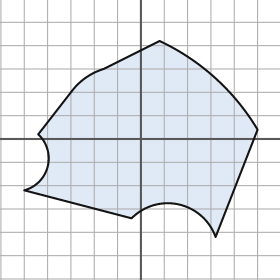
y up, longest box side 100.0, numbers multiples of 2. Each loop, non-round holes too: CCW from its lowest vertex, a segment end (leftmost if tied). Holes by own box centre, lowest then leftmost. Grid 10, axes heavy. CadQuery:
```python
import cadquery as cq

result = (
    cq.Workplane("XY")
    .moveTo(32.0, -42.0)
    .lineTo(50.0, 4.0)
    .threePointArc((32.0, 26.0), (8.0, 42.0))
    .lineTo(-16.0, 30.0)
    .threePointArc((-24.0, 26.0), (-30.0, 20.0))
    .lineTo(-44.0, 2.0)
    .threePointArc((-40.0, -12.0), (-50.0, -22.0))
    .lineTo(-4.0, -34.0)
    .threePointArc((16.0, -28.0), (32.0, -42.0))
    .close()
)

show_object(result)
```